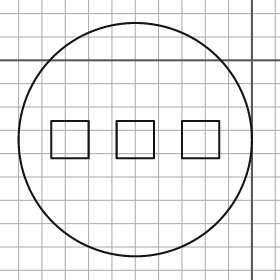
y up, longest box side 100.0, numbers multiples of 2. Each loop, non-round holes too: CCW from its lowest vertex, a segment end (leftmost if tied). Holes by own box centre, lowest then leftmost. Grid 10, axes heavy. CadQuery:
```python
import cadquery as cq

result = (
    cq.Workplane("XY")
    .moveTo(-50.0, -34.0)
    .circle(50.0)
    .moveTo(-86.0, -42.0)
    .lineTo(-70.0, -42.0)
    .lineTo(-70.0, -26.0)
    .lineTo(-86.0, -26.0)
    .close()
    .moveTo(-58.0, -42.0)
    .lineTo(-42.0, -42.0)
    .lineTo(-42.0, -26.0)
    .lineTo(-58.0, -26.0)
    .close()
    .moveTo(-30.0, -42.0)
    .lineTo(-14.0, -42.0)
    .lineTo(-14.0, -26.0)
    .lineTo(-30.0, -26.0)
    .close()
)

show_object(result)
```